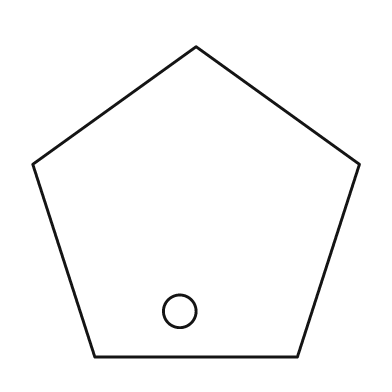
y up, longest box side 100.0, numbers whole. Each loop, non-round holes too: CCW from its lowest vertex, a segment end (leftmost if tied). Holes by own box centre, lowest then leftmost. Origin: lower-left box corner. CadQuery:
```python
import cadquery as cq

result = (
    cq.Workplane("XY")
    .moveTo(19.0, 0.0)
    .lineTo(81.0, 0.0)
    .lineTo(100.0, 59.0)
    .lineTo(50.0, 95.0)
    .lineTo(0.0, 59.0)
    .close()
    .moveTo(45.0, 14.0)
    .circle(5.0)
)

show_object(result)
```